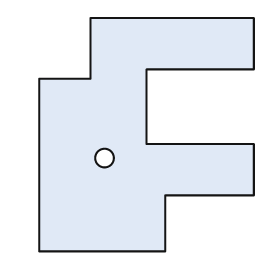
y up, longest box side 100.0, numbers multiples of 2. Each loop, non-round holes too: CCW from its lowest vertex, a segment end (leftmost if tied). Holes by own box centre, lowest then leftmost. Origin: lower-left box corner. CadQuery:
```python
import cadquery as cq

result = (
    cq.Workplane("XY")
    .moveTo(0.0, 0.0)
    .lineTo(54.0, 0.0)
    .lineTo(54.0, 24.0)
    .lineTo(92.0, 24.0)
    .lineTo(92.0, 46.0)
    .lineTo(46.0, 46.0)
    .lineTo(46.0, 78.0)
    .lineTo(92.0, 78.0)
    .lineTo(92.0, 100.0)
    .lineTo(22.0, 100.0)
    .lineTo(22.0, 74.0)
    .lineTo(0.0, 74.0)
    .close()
    .moveTo(28.0, 40.0)
    .circle(4.0)
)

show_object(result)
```